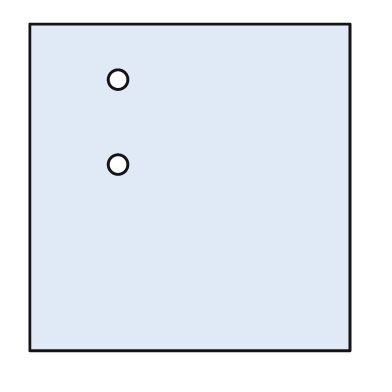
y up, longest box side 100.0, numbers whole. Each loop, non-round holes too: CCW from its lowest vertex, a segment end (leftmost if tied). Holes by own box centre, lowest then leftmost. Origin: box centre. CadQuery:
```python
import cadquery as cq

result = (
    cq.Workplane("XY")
    .moveTo(-49.0, -50.0)
    .lineTo(49.0, -50.0)
    .lineTo(49.0, 50.0)
    .lineTo(-49.0, 50.0)
    .close()
    .moveTo(-22.0, 7.0)
    .circle(3.0)
    .moveTo(-22.0, 33.0)
    .circle(3.0)
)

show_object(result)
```